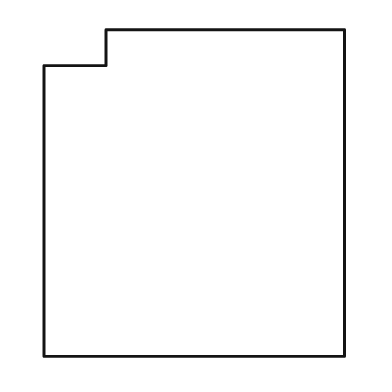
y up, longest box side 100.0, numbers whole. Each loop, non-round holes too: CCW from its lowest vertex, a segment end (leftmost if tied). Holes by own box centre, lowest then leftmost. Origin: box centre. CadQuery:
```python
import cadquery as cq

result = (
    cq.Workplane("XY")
    .moveTo(-46.0, -50.0)
    .lineTo(46.0, -50.0)
    .lineTo(46.0, 50.0)
    .lineTo(-27.0, 50.0)
    .lineTo(-27.0, 39.0)
    .lineTo(-46.0, 39.0)
    .close()
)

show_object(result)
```